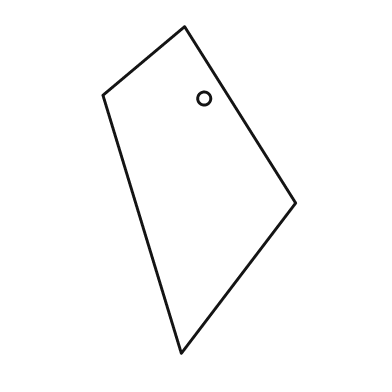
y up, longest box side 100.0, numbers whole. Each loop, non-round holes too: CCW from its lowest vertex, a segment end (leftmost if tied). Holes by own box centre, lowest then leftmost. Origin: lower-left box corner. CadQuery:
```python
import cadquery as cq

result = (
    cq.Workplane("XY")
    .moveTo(24.0, 0.0)
    .lineTo(59.0, 46.0)
    .lineTo(25.0, 100.0)
    .lineTo(0.0, 79.0)
    .close()
    .moveTo(31.0, 78.0)
    .circle(2.0)
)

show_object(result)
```